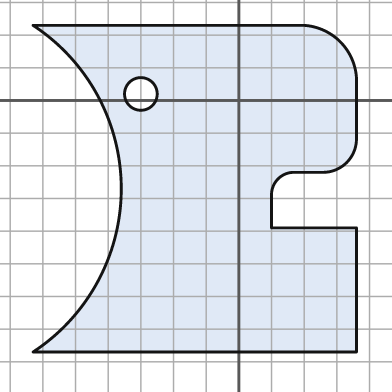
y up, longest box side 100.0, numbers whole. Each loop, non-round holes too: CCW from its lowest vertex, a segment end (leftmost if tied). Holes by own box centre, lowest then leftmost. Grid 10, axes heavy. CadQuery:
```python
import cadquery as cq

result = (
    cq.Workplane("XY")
    .moveTo(-63.0, -77.0)
    .lineTo(36.0, -77.0)
    .lineTo(36.0, -39.0)
    .lineTo(10.0, -39.0)
    .lineTo(10.0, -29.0)
    .threePointArc((12.0, -24.0), (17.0, -22.0))
    .lineTo(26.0, -22.0)
    .threePointArc((33.0, -19.0), (36.0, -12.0))
    .lineTo(36.0, 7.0)
    .threePointArc((31.0, 18.0), (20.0, 23.0))
    .lineTo(-63.0, 23.0)
    .threePointArc((-36.0, -27.0), (-63.0, -77.0))
    .close()
    .moveTo(-30.0, 2.0)
    .circle(5.0)
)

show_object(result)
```